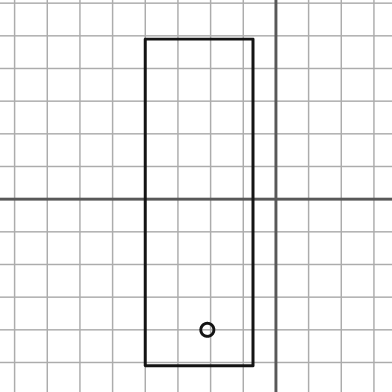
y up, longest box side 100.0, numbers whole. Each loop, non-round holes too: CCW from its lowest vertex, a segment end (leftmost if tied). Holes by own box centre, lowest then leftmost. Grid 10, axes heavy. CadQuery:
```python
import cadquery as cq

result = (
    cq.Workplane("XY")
    .moveTo(-40.0, -51.0)
    .lineTo(-7.0, -51.0)
    .lineTo(-7.0, 49.0)
    .lineTo(-40.0, 49.0)
    .close()
    .moveTo(-21.0, -40.0)
    .circle(2.0)
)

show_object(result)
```